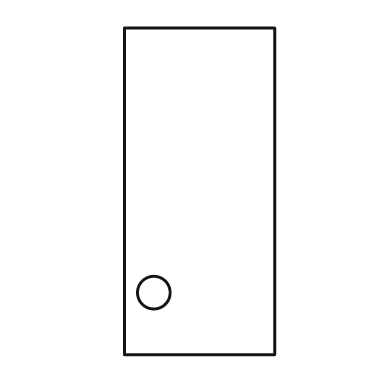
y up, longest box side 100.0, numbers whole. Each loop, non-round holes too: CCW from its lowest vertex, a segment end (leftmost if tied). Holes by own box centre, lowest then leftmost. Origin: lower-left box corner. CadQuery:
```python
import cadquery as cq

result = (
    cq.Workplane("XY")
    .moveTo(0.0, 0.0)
    .lineTo(46.0, 0.0)
    .lineTo(46.0, 100.0)
    .lineTo(0.0, 100.0)
    .close()
    .moveTo(9.0, 19.0)
    .circle(5.0)
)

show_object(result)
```